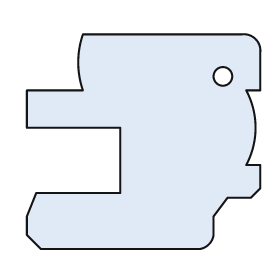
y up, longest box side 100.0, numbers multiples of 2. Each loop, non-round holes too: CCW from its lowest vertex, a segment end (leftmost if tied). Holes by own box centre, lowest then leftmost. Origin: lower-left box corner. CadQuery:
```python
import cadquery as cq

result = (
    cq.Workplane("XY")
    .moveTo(6.0, 0.0)
    .lineTo(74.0, 0.0)
    .threePointArc((78.0, 2.0), (80.0, 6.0))
    .lineTo(80.0, 14.0)
    .lineTo(86.0, 22.0)
    .lineTo(96.0, 22.0)
    .lineTo(100.0, 26.0)
    .lineTo(100.0, 36.0)
    .lineTo(94.0, 36.0)
    .threePointArc((98.0, 52.0), (94.0, 68.0))
    .lineTo(100.0, 68.0)
    .lineTo(100.0, 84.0)
    .threePointArc((98.0, 90.0), (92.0, 92.0))
    .lineTo(24.0, 92.0)
    .threePointArc((22.0, 80.0), (24.0, 68.0))
    .lineTo(0.0, 68.0)
    .lineTo(0.0, 52.0)
    .lineTo(40.0, 52.0)
    .lineTo(40.0, 24.0)
    .lineTo(4.0, 24.0)
    .lineTo(0.0, 14.0)
    .lineTo(0.0, 6.0)
    .close()
    .moveTo(84.0, 74.0)
    .circle(4.0)
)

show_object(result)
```